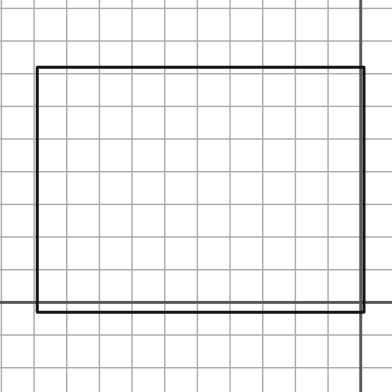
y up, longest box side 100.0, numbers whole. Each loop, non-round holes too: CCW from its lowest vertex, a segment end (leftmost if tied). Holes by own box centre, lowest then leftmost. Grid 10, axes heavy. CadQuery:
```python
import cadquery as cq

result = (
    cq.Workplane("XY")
    .moveTo(-99.0, -3.0)
    .lineTo(1.0, -3.0)
    .lineTo(1.0, 72.0)
    .lineTo(-99.0, 72.0)
    .close()
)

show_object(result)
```